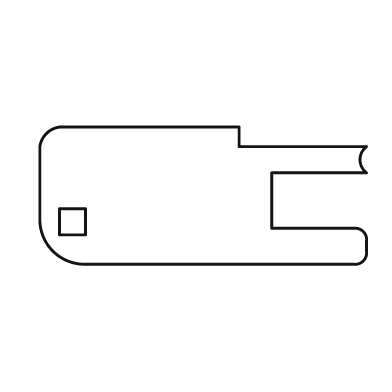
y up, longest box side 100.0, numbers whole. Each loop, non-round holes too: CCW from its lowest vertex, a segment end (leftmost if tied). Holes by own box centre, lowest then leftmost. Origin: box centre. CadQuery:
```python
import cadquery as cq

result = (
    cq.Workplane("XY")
    .moveTo(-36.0, -21.0)
    .lineTo(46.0, -21.0)
    .threePointArc((49.0, -20.0), (50.0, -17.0))
    .lineTo(50.0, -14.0)
    .threePointArc((49.0, -11.0), (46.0, -10.0))
    .lineTo(21.0, -10.0)
    .lineTo(21.0, 7.0)
    .lineTo(50.0, 7.0)
    .threePointArc((48.0, 11.0), (50.0, 15.0))
    .lineTo(11.0, 15.0)
    .lineTo(11.0, 21.0)
    .lineTo(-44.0, 21.0)
    .threePointArc((-48.0, 19.0), (-50.0, 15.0))
    .lineTo(-50.0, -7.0)
    .threePointArc((-46.0, -17.0), (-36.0, -21.0))
    .close()
    .moveTo(-44.0, -12.0)
    .lineTo(-36.0, -12.0)
    .lineTo(-36.0, -4.0)
    .lineTo(-44.0, -4.0)
    .close()
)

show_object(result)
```